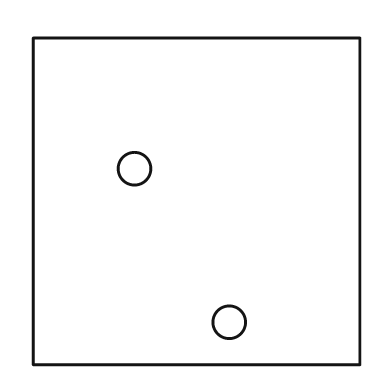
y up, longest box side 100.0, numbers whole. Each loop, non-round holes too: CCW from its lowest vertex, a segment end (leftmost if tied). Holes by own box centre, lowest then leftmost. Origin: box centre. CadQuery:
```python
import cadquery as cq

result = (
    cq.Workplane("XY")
    .moveTo(-50.0, -50.0)
    .lineTo(50.0, -50.0)
    .lineTo(50.0, 50.0)
    .lineTo(-50.0, 50.0)
    .close()
    .moveTo(10.0, -37.0)
    .circle(5.0)
    .moveTo(-19.0, 10.0)
    .circle(5.0)
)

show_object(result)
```